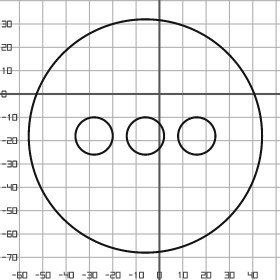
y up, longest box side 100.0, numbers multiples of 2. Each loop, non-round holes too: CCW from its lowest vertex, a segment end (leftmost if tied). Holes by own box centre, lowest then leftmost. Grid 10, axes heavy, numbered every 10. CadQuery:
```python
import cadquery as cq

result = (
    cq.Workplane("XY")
    .moveTo(-6.0, -18.0)
    .circle(50.0)
    .moveTo(-28.0, -18.0)
    .circle(8.0)
    .moveTo(-6.0, -18.0)
    .circle(8.0)
    .moveTo(16.0, -18.0)
    .circle(8.0)
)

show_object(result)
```